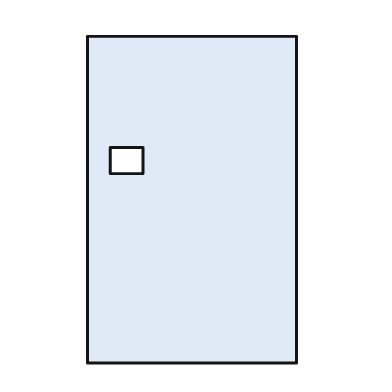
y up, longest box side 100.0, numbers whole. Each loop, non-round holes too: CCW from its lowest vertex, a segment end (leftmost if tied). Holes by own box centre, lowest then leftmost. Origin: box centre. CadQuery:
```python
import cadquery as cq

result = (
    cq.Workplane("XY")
    .moveTo(-32.0, -50.0)
    .lineTo(32.0, -50.0)
    .lineTo(32.0, 50.0)
    .lineTo(-32.0, 50.0)
    .close()
    .moveTo(-25.0, 8.0)
    .lineTo(-15.0, 8.0)
    .lineTo(-15.0, 16.0)
    .lineTo(-25.0, 16.0)
    .close()
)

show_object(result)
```